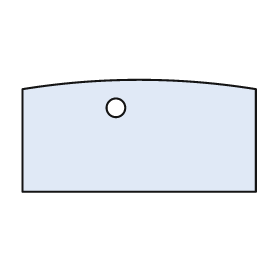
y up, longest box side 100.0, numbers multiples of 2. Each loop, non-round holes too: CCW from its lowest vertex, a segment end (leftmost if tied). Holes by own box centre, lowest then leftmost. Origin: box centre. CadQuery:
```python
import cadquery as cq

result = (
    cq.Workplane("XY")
    .moveTo(-50.0, -24.0)
    .lineTo(50.0, -24.0)
    .lineTo(50.0, 20.0)
    .threePointArc((0.0, 24.0), (-50.0, 20.0))
    .close()
    .moveTo(-10.0, 12.0)
    .circle(4.0)
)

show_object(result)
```